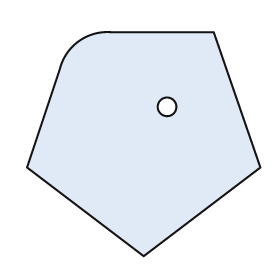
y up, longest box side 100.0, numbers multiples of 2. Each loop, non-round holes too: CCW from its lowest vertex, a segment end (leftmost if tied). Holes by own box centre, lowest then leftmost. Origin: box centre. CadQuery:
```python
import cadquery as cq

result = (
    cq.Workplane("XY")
    .moveTo(0.0, -48.0)
    .lineTo(50.0, -10.0)
    .lineTo(30.0, 48.0)
    .lineTo(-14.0, 48.0)
    .threePointArc((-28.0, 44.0), (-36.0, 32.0))
    .lineTo(-50.0, -10.0)
    .close()
    .moveTo(10.0, 16.0)
    .circle(4.0)
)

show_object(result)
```